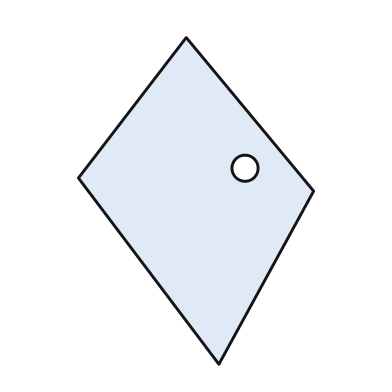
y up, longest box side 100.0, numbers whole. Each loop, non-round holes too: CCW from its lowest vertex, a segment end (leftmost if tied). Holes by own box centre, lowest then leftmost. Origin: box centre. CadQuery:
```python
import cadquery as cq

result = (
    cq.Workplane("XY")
    .moveTo(7.0, -50.0)
    .lineTo(36.0, 3.0)
    .lineTo(-3.0, 50.0)
    .lineTo(-36.0, 7.0)
    .close()
    .moveTo(15.0, 10.0)
    .circle(4.0)
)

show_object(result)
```